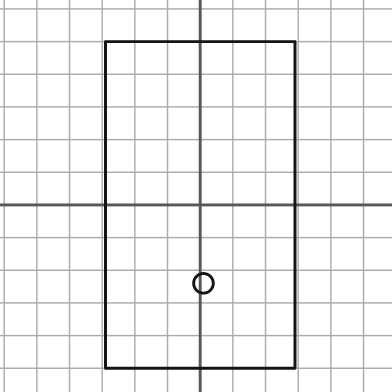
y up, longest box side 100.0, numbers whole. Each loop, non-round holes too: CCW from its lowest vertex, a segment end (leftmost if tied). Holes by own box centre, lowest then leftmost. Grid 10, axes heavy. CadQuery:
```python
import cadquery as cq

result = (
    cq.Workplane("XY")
    .moveTo(-29.0, -50.0)
    .lineTo(29.0, -50.0)
    .lineTo(29.0, 50.0)
    .lineTo(-29.0, 50.0)
    .close()
    .moveTo(1.0, -24.0)
    .circle(3.0)
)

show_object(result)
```